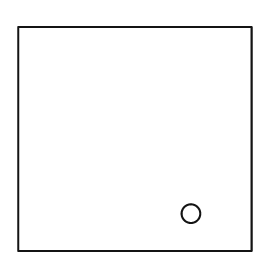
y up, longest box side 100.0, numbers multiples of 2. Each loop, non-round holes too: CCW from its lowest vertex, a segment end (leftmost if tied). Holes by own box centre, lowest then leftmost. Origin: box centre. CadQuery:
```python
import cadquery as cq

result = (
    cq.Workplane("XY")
    .moveTo(-50.0, -48.0)
    .lineTo(50.0, -48.0)
    .lineTo(50.0, 48.0)
    .lineTo(-50.0, 48.0)
    .close()
    .moveTo(24.0, -32.0)
    .circle(4.0)
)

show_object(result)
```